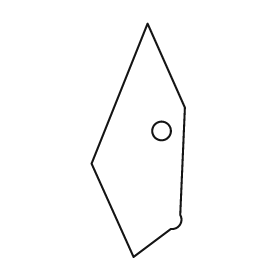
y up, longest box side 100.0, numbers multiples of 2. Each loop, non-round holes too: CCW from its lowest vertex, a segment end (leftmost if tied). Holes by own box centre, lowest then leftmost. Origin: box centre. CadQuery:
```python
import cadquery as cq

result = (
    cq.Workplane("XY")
    .moveTo(-2.0, -50.0)
    .lineTo(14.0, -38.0)
    .threePointArc((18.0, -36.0), (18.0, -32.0))
    .lineTo(20.0, 14.0)
    .lineTo(4.0, 50.0)
    .lineTo(-20.0, -10.0)
    .close()
    .moveTo(10.0, 4.0)
    .circle(4.0)
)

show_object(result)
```